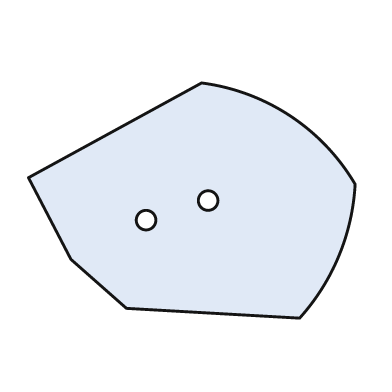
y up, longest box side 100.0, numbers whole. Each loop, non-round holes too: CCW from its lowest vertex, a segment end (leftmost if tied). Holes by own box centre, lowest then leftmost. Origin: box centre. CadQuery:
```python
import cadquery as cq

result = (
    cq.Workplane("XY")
    .moveTo(33.0, -36.0)
    .threePointArc((45.0, -17.0), (50.0, 5.0))
    .threePointArc((30.0, 26.0), (3.0, 36.0))
    .lineTo(-50.0, 7.0)
    .lineTo(-37.0, -18.0)
    .lineTo(-20.0, -33.0)
    .close()
    .moveTo(-14.0, -6.0)
    .circle(3.0)
    .moveTo(5.0, 0.0)
    .circle(3.0)
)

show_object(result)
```